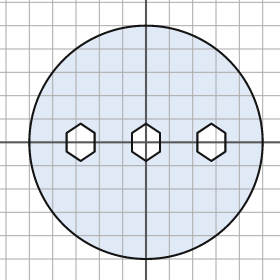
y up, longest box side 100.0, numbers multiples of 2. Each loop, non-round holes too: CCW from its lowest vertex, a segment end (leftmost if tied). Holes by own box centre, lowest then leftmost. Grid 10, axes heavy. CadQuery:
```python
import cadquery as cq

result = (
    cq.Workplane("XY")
    .moveTo(0.0, 0.0)
    .circle(50.0)
    .moveTo(-28.0, -8.0)
    .lineTo(-22.0, -4.0)
    .lineTo(-22.0, 4.0)
    .lineTo(-28.0, 8.0)
    .lineTo(-34.0, 4.0)
    .lineTo(-34.0, -4.0)
    .close()
    .moveTo(0.0, -8.0)
    .lineTo(6.0, -4.0)
    .lineTo(6.0, 4.0)
    .lineTo(0.0, 8.0)
    .lineTo(-6.0, 4.0)
    .lineTo(-6.0, -4.0)
    .close()
    .moveTo(28.0, -8.0)
    .lineTo(34.0, -4.0)
    .lineTo(34.0, 4.0)
    .lineTo(28.0, 8.0)
    .lineTo(22.0, 4.0)
    .lineTo(22.0, -4.0)
    .close()
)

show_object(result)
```